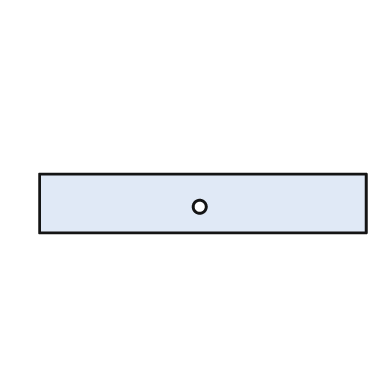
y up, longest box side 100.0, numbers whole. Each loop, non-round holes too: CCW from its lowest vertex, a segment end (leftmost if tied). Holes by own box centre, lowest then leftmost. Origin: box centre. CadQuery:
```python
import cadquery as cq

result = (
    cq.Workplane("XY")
    .moveTo(-50.0, -9.0)
    .lineTo(50.0, -9.0)
    .lineTo(50.0, 9.0)
    .lineTo(-50.0, 9.0)
    .close()
    .moveTo(-1.0, -1.0)
    .circle(2.0)
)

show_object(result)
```